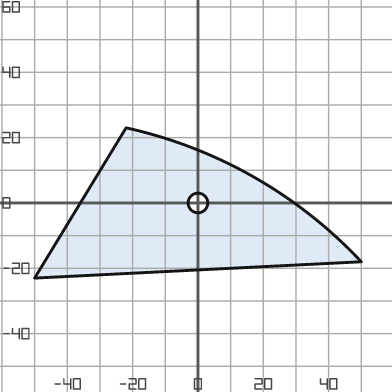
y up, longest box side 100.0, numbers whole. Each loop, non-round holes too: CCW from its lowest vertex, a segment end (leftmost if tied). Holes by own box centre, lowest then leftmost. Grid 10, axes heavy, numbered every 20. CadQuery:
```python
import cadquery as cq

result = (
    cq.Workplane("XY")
    .moveTo(-50.0, -23.0)
    .lineTo(50.0, -18.0)
    .threePointArc((17.0, 8.0), (-22.0, 23.0))
    .close()
    .moveTo(0.0, 0.0)
    .circle(3.0)
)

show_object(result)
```